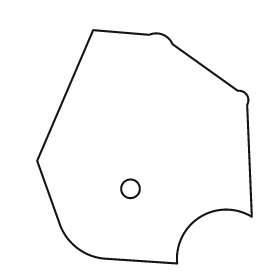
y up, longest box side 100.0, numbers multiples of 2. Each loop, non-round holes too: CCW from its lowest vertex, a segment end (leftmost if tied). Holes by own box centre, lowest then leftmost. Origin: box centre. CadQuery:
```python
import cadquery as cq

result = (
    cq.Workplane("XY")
    .moveTo(14.0, -50.0)
    .threePointArc((24.0, -30.0), (46.0, -30.0))
    .lineTo(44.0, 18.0)
    .threePointArc((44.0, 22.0), (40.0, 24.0))
    .lineTo(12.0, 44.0)
    .threePointArc((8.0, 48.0), (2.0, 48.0))
    .lineTo(-22.0, 50.0)
    .lineTo(-46.0, -6.0)
    .lineTo(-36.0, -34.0)
    .threePointArc((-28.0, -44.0), (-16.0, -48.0))
    .close()
    .moveTo(-6.0, -18.0)
    .circle(4.0)
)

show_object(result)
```